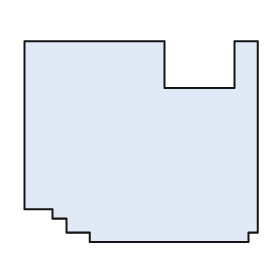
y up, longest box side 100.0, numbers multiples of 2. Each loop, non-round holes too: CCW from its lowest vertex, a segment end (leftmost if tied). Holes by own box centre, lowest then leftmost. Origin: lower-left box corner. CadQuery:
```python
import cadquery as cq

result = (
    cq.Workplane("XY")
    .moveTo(28.0, 0.0)
    .lineTo(96.0, 0.0)
    .lineTo(96.0, 4.0)
    .lineTo(100.0, 4.0)
    .lineTo(100.0, 86.0)
    .lineTo(90.0, 86.0)
    .lineTo(90.0, 66.0)
    .lineTo(60.0, 66.0)
    .lineTo(60.0, 86.0)
    .lineTo(0.0, 86.0)
    .lineTo(0.0, 14.0)
    .lineTo(12.0, 14.0)
    .lineTo(12.0, 10.0)
    .lineTo(18.0, 10.0)
    .lineTo(18.0, 4.0)
    .lineTo(28.0, 4.0)
    .close()
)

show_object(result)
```